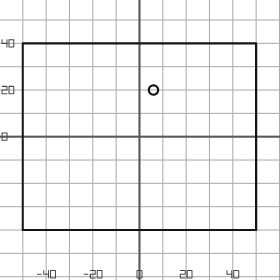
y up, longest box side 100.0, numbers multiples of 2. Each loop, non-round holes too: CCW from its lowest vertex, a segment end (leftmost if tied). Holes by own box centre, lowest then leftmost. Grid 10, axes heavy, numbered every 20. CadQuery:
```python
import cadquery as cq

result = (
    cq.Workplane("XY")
    .moveTo(-50.0, -40.0)
    .lineTo(50.0, -40.0)
    .lineTo(50.0, 40.0)
    .lineTo(-50.0, 40.0)
    .close()
    .moveTo(6.0, 20.0)
    .circle(2.0)
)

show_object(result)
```